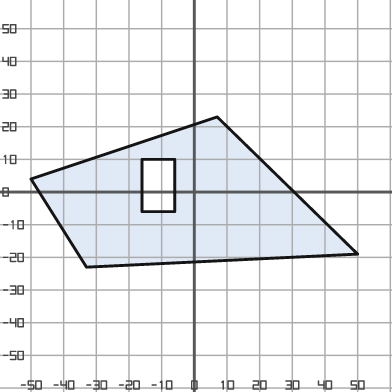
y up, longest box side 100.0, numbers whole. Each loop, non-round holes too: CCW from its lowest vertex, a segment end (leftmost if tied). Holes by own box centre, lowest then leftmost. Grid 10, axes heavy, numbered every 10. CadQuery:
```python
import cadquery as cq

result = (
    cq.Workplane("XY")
    .moveTo(-33.0, -23.0)
    .lineTo(50.0, -19.0)
    .lineTo(7.0, 23.0)
    .lineTo(-50.0, 4.0)
    .close()
    .moveTo(-16.0, -6.0)
    .lineTo(-6.0, -6.0)
    .lineTo(-6.0, 10.0)
    .lineTo(-16.0, 10.0)
    .close()
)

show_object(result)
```